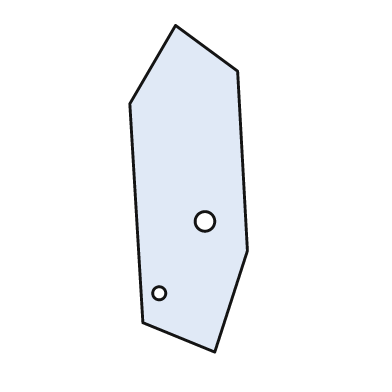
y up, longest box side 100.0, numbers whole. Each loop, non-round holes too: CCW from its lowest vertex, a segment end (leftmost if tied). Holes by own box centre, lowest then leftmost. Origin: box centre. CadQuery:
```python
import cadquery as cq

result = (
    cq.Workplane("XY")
    .moveTo(8.0, -50.0)
    .lineTo(18.0, -19.0)
    .lineTo(15.0, 36.0)
    .lineTo(-4.0, 50.0)
    .lineTo(-18.0, 26.0)
    .lineTo(-14.0, -41.0)
    .close()
    .moveTo(-9.0, -32.0)
    .circle(2.0)
    .moveTo(5.0, -10.0)
    .circle(3.0)
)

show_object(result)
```